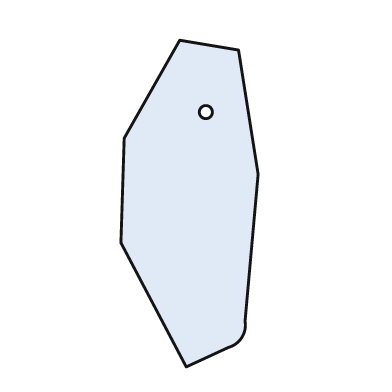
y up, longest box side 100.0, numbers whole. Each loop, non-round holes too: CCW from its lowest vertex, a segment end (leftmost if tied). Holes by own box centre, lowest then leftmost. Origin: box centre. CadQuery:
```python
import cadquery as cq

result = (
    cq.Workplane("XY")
    .moveTo(-1.0, -50.0)
    .lineTo(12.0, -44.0)
    .threePointArc((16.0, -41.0), (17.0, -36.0))
    .lineTo(21.0, 9.0)
    .lineTo(15.0, 47.0)
    .lineTo(-3.0, 50.0)
    .lineTo(-20.0, 20.0)
    .lineTo(-21.0, -12.0)
    .close()
    .moveTo(5.0, 28.0)
    .circle(2.0)
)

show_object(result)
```